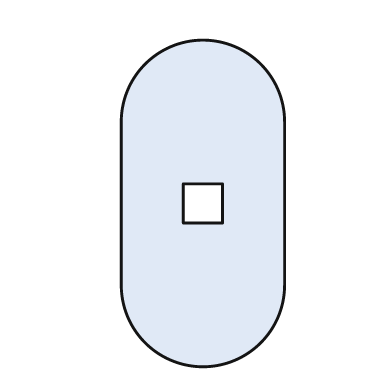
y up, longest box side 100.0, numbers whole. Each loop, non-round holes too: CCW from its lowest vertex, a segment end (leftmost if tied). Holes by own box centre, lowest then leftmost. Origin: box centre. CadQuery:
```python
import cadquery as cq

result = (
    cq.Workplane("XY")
    .moveTo(-25.0, -25.0)
    .threePointArc((0.0, -50.0), (25.0, -25.0))
    .lineTo(25.0, 25.0)
    .threePointArc((0.0, 50.0), (-25.0, 25.0))
    .close()
    .moveTo(-6.0, -6.0)
    .lineTo(6.0, -6.0)
    .lineTo(6.0, 6.0)
    .lineTo(-6.0, 6.0)
    .close()
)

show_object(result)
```